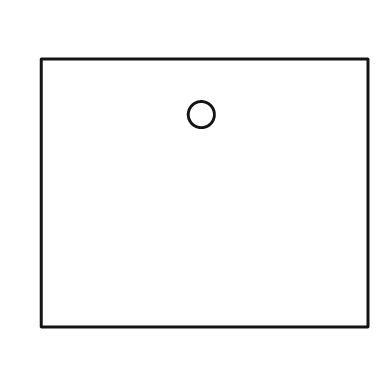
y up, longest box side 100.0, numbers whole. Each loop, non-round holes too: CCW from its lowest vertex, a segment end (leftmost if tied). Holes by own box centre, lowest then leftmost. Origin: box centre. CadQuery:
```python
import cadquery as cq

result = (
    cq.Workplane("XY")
    .moveTo(-50.0, -41.0)
    .lineTo(50.0, -41.0)
    .lineTo(50.0, 41.0)
    .lineTo(-50.0, 41.0)
    .close()
    .moveTo(-1.0, 24.0)
    .circle(4.0)
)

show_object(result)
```